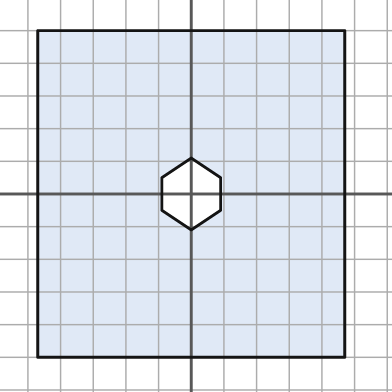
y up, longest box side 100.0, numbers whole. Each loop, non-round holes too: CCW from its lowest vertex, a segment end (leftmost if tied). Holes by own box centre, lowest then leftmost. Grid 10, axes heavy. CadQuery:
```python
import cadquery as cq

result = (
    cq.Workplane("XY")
    .moveTo(-47.0, -50.0)
    .lineTo(47.0, -50.0)
    .lineTo(47.0, 50.0)
    .lineTo(-47.0, 50.0)
    .close()
    .moveTo(0.0, -11.0)
    .lineTo(9.0, -5.0)
    .lineTo(9.0, 5.0)
    .lineTo(0.0, 11.0)
    .lineTo(-9.0, 5.0)
    .lineTo(-9.0, -5.0)
    .close()
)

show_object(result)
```